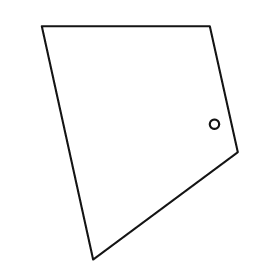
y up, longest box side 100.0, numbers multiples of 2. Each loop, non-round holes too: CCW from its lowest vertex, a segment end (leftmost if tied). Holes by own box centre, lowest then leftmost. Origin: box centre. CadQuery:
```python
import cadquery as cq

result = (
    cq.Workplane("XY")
    .moveTo(-20.0, -50.0)
    .lineTo(42.0, -4.0)
    .lineTo(30.0, 50.0)
    .lineTo(-42.0, 50.0)
    .close()
    .moveTo(32.0, 8.0)
    .circle(2.0)
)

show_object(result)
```